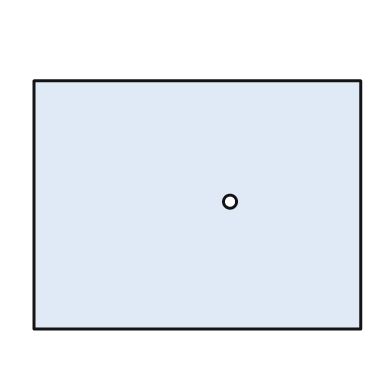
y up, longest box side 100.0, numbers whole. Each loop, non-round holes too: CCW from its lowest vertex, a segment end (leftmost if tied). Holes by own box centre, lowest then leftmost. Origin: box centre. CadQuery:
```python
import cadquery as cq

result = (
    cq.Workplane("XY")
    .moveTo(-50.0, -38.0)
    .lineTo(50.0, -38.0)
    .lineTo(50.0, 38.0)
    .lineTo(-50.0, 38.0)
    .close()
    .moveTo(10.0, 1.0)
    .circle(2.0)
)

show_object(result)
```